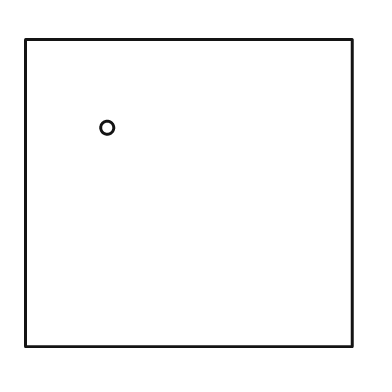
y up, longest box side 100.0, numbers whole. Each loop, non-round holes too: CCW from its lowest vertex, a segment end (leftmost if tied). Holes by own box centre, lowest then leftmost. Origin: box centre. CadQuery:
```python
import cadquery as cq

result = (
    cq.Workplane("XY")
    .moveTo(-50.0, -47.0)
    .lineTo(50.0, -47.0)
    .lineTo(50.0, 47.0)
    .lineTo(-50.0, 47.0)
    .close()
    .moveTo(-25.0, 20.0)
    .circle(2.0)
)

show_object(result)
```